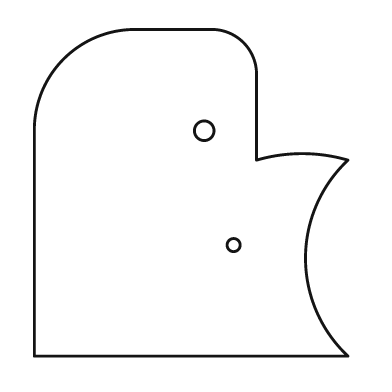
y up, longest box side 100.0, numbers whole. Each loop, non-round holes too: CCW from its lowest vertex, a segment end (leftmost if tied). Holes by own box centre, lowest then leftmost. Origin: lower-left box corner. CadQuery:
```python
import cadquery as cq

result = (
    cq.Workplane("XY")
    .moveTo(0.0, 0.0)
    .lineTo(96.0, 0.0)
    .threePointArc((83.0, 30.0), (96.0, 60.0))
    .threePointArc((82.0, 62.0), (68.0, 60.0))
    .lineTo(68.0, 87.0)
    .threePointArc((64.0, 96.0), (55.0, 100.0))
    .lineTo(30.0, 100.0)
    .threePointArc((9.0, 91.0), (0.0, 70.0))
    .close()
    .moveTo(61.0, 34.0)
    .circle(2.0)
    .moveTo(52.0, 69.0)
    .circle(3.0)
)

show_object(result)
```